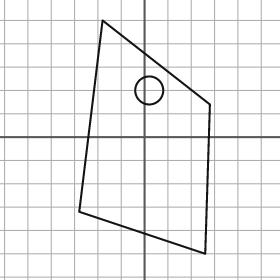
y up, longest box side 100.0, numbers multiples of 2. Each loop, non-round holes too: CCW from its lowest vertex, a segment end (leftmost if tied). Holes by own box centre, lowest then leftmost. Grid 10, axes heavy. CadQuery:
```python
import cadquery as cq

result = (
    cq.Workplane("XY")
    .moveTo(26.0, -50.0)
    .lineTo(28.0, 14.0)
    .lineTo(-18.0, 50.0)
    .lineTo(-28.0, -32.0)
    .close()
    .moveTo(2.0, 20.0)
    .circle(6.0)
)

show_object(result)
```